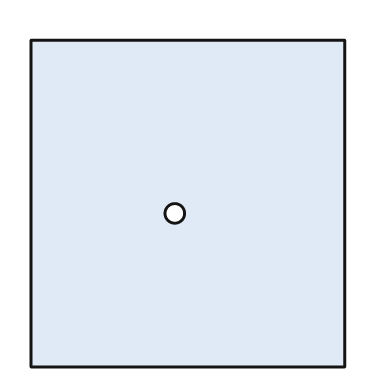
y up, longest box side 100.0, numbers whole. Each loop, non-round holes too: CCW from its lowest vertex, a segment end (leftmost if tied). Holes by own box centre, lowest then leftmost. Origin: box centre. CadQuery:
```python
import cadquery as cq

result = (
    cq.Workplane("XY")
    .moveTo(-48.0, -50.0)
    .lineTo(48.0, -50.0)
    .lineTo(48.0, 50.0)
    .lineTo(-48.0, 50.0)
    .close()
    .moveTo(-4.0, -3.0)
    .circle(3.0)
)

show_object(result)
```